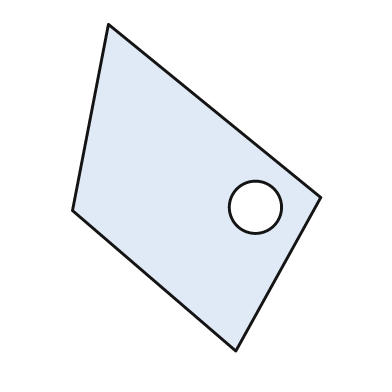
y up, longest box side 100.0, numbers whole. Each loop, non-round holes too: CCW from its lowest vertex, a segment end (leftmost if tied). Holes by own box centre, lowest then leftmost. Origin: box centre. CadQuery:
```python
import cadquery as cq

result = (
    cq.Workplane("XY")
    .moveTo(12.0, -50.0)
    .lineTo(38.0, -3.0)
    .lineTo(-27.0, 50.0)
    .lineTo(-38.0, -7.0)
    .close()
    .moveTo(18.0, -6.0)
    .circle(8.0)
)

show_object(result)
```